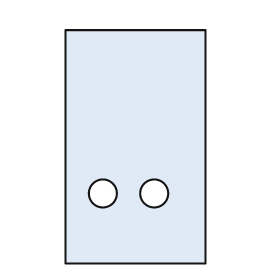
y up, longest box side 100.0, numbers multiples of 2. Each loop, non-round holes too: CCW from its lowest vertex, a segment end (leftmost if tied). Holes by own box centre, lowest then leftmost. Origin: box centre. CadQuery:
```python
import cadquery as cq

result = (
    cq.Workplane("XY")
    .moveTo(-30.0, -50.0)
    .lineTo(30.0, -50.0)
    .lineTo(30.0, 50.0)
    .lineTo(-30.0, 50.0)
    .close()
    .moveTo(-14.0, -20.0)
    .circle(6.0)
    .moveTo(8.0, -20.0)
    .circle(6.0)
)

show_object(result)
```